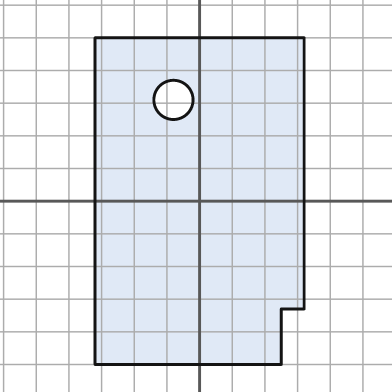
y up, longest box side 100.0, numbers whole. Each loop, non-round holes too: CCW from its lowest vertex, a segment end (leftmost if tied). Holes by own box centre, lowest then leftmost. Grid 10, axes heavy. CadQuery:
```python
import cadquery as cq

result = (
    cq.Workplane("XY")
    .moveTo(-32.0, -50.0)
    .lineTo(25.0, -50.0)
    .lineTo(25.0, -33.0)
    .lineTo(32.0, -33.0)
    .lineTo(32.0, 50.0)
    .lineTo(-32.0, 50.0)
    .close()
    .moveTo(-8.0, 31.0)
    .circle(6.0)
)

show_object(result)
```